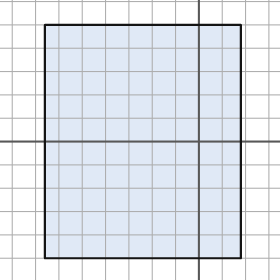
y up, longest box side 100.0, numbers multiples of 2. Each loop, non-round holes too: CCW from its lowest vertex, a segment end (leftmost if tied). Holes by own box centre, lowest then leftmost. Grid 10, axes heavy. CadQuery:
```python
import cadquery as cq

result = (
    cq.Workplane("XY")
    .moveTo(-66.0, -50.0)
    .lineTo(18.0, -50.0)
    .lineTo(18.0, 50.0)
    .lineTo(-66.0, 50.0)
    .close()
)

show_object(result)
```